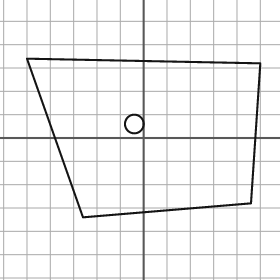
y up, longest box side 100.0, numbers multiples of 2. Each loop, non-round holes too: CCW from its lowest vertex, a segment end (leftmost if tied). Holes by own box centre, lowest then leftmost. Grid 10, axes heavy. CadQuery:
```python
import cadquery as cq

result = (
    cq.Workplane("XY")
    .moveTo(-26.0, -34.0)
    .lineTo(46.0, -28.0)
    .lineTo(50.0, 32.0)
    .lineTo(-50.0, 34.0)
    .close()
    .moveTo(-4.0, 6.0)
    .circle(4.0)
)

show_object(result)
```